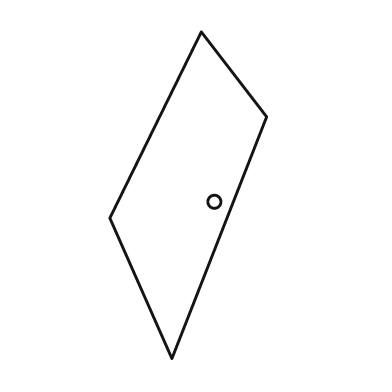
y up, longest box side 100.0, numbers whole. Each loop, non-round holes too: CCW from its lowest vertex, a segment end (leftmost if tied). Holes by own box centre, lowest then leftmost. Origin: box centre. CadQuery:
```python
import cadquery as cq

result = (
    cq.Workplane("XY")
    .moveTo(-5.0, -50.0)
    .lineTo(24.0, 24.0)
    .lineTo(4.0, 50.0)
    .lineTo(-24.0, -7.0)
    .close()
    .moveTo(8.0, -2.0)
    .circle(2.0)
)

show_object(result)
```